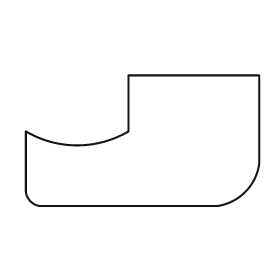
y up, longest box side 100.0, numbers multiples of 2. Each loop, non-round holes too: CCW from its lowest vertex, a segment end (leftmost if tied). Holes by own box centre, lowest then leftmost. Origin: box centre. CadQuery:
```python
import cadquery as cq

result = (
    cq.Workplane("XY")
    .moveTo(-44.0, -28.0)
    .lineTo(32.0, -28.0)
    .threePointArc((44.0, -22.0), (50.0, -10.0))
    .lineTo(50.0, 28.0)
    .lineTo(-6.0, 28.0)
    .lineTo(-6.0, 4.0)
    .threePointArc((-28.0, -2.0), (-50.0, 4.0))
    .lineTo(-50.0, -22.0)
    .threePointArc((-48.0, -26.0), (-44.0, -28.0))
    .close()
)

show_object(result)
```